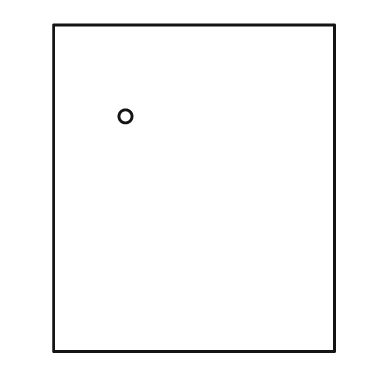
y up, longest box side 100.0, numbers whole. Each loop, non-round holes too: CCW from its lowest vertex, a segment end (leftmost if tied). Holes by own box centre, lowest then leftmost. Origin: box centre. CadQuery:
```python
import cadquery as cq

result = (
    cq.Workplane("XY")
    .moveTo(-43.0, -50.0)
    .lineTo(43.0, -50.0)
    .lineTo(43.0, 50.0)
    .lineTo(-43.0, 50.0)
    .close()
    .moveTo(-21.0, 22.0)
    .circle(2.0)
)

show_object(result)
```